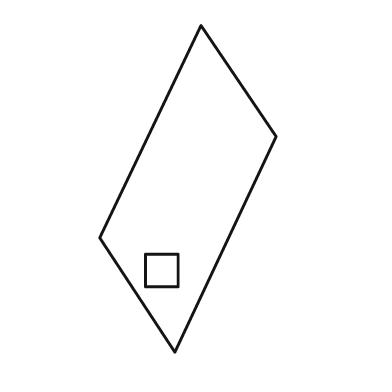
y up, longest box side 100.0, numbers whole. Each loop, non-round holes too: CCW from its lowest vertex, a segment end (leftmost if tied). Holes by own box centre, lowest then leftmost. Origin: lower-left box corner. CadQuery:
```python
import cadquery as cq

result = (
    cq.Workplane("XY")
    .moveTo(23.0, 0.0)
    .lineTo(54.0, 66.0)
    .lineTo(31.0, 100.0)
    .lineTo(0.0, 35.0)
    .close()
    .moveTo(14.0, 20.0)
    .lineTo(24.0, 20.0)
    .lineTo(24.0, 30.0)
    .lineTo(14.0, 30.0)
    .close()
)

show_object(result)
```